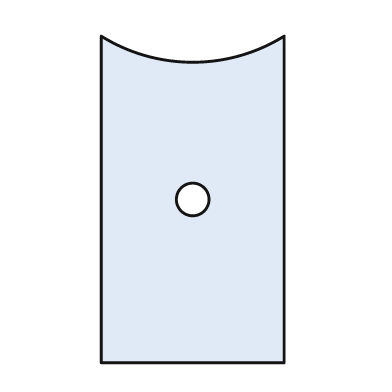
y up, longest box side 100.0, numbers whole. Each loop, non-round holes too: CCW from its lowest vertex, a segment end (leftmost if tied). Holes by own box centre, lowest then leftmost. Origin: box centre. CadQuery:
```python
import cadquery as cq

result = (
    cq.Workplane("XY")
    .moveTo(-28.0, -50.0)
    .lineTo(28.0, -50.0)
    .lineTo(28.0, 50.0)
    .threePointArc((0.0, 42.0), (-28.0, 50.0))
    .close()
    .moveTo(0.0, 0.0)
    .circle(5.0)
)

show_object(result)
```